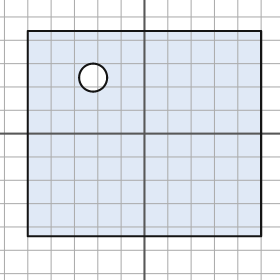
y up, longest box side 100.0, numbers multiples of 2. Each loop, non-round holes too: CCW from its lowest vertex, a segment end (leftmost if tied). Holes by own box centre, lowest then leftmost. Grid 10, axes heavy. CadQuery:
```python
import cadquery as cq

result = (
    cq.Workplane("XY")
    .moveTo(-50.0, -44.0)
    .lineTo(50.0, -44.0)
    .lineTo(50.0, 44.0)
    .lineTo(-50.0, 44.0)
    .close()
    .moveTo(-22.0, 24.0)
    .circle(6.0)
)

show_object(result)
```